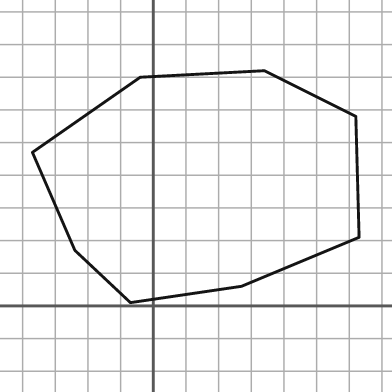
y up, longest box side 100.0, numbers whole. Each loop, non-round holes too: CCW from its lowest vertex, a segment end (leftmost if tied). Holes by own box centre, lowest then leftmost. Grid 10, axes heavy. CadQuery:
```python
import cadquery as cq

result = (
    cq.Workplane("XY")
    .moveTo(-7.0, 1.0)
    .lineTo(27.0, 6.0)
    .lineTo(63.0, 21.0)
    .lineTo(62.0, 58.0)
    .lineTo(34.0, 72.0)
    .lineTo(-4.0, 70.0)
    .lineTo(-37.0, 47.0)
    .lineTo(-24.0, 17.0)
    .close()
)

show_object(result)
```